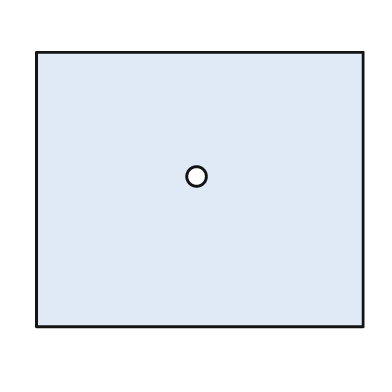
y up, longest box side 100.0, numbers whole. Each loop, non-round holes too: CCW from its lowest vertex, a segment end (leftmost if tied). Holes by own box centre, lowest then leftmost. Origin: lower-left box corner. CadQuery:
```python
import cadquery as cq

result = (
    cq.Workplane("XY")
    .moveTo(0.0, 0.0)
    .lineTo(100.0, 0.0)
    .lineTo(100.0, 84.0)
    .lineTo(0.0, 84.0)
    .close()
    .moveTo(49.0, 46.0)
    .circle(3.0)
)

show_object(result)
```